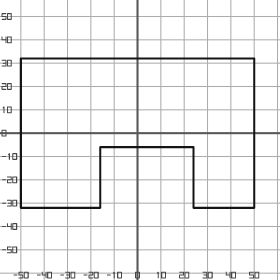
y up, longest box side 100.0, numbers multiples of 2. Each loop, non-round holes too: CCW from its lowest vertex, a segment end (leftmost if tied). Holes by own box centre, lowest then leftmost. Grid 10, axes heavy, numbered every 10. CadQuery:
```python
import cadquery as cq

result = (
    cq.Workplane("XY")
    .moveTo(-50.0, -32.0)
    .lineTo(-16.0, -32.0)
    .lineTo(-16.0, -6.0)
    .lineTo(24.0, -6.0)
    .lineTo(24.0, -32.0)
    .lineTo(50.0, -32.0)
    .lineTo(50.0, 32.0)
    .lineTo(-50.0, 32.0)
    .close()
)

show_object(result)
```